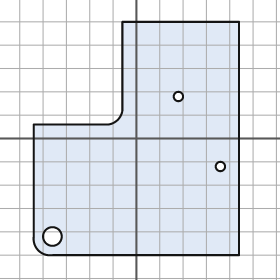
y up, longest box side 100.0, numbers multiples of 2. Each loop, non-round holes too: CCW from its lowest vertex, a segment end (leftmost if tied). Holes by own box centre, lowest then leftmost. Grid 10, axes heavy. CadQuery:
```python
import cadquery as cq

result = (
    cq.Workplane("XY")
    .moveTo(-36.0, -50.0)
    .lineTo(44.0, -50.0)
    .lineTo(44.0, 50.0)
    .lineTo(-6.0, 50.0)
    .lineTo(-6.0, 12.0)
    .threePointArc((-8.0, 8.0), (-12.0, 6.0))
    .lineTo(-44.0, 6.0)
    .lineTo(-44.0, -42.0)
    .threePointArc((-42.0, -48.0), (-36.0, -50.0))
    .close()
    .moveTo(-36.0, -42.0)
    .circle(4.0)
    .moveTo(36.0, -12.0)
    .circle(2.0)
    .moveTo(18.0, 18.0)
    .circle(2.0)
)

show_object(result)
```